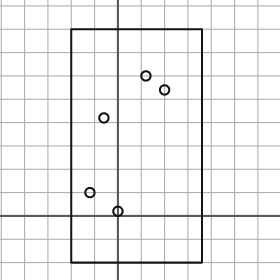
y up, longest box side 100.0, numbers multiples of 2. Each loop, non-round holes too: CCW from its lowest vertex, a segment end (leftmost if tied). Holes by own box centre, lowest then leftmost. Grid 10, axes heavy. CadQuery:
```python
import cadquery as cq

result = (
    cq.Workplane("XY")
    .moveTo(-20.0, -20.0)
    .lineTo(36.0, -20.0)
    .lineTo(36.0, 80.0)
    .lineTo(-20.0, 80.0)
    .close()
    .moveTo(0.0, 2.0)
    .circle(2.0)
    .moveTo(-12.0, 10.0)
    .circle(2.0)
    .moveTo(-6.0, 42.0)
    .circle(2.0)
    .moveTo(20.0, 54.0)
    .circle(2.0)
    .moveTo(12.0, 60.0)
    .circle(2.0)
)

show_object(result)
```